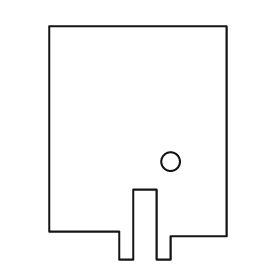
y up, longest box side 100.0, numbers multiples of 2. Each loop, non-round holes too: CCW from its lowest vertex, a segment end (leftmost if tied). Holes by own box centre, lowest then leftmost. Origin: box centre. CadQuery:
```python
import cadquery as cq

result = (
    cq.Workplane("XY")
    .moveTo(-8.0, -50.0)
    .lineTo(-2.0, -50.0)
    .lineTo(-2.0, -20.0)
    .lineTo(8.0, -20.0)
    .lineTo(8.0, -50.0)
    .lineTo(14.0, -50.0)
    .lineTo(14.0, -40.0)
    .lineTo(38.0, -40.0)
    .lineTo(38.0, 50.0)
    .lineTo(-38.0, 50.0)
    .lineTo(-38.0, -38.0)
    .lineTo(-8.0, -38.0)
    .close()
    .moveTo(14.0, -8.0)
    .circle(4.0)
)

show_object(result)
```